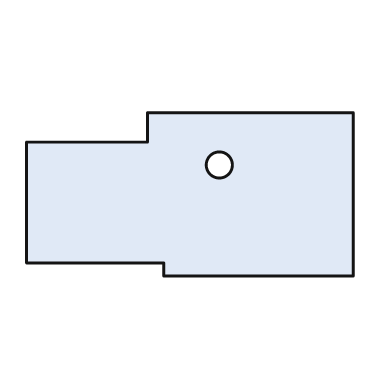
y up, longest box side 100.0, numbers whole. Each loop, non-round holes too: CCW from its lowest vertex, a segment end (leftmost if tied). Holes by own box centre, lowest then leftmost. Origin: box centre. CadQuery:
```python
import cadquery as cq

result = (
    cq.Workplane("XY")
    .moveTo(-8.0, -25.0)
    .lineTo(50.0, -25.0)
    .lineTo(50.0, 25.0)
    .lineTo(-13.0, 25.0)
    .lineTo(-13.0, 16.0)
    .lineTo(-50.0, 16.0)
    .lineTo(-50.0, -21.0)
    .lineTo(-8.0, -21.0)
    .close()
    .moveTo(9.0, 9.0)
    .circle(4.0)
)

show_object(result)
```